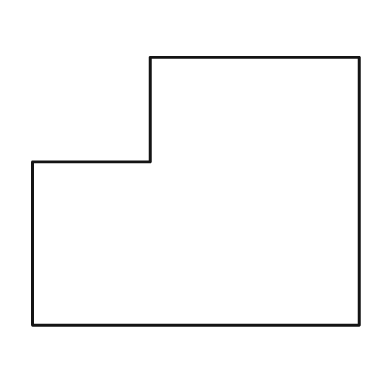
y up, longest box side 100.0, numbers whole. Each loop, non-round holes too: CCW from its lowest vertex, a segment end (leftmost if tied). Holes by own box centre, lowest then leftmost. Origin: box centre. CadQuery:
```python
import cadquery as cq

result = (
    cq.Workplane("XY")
    .moveTo(-50.0, -41.0)
    .lineTo(50.0, -41.0)
    .lineTo(50.0, 41.0)
    .lineTo(-14.0, 41.0)
    .lineTo(-14.0, 9.0)
    .lineTo(-50.0, 9.0)
    .close()
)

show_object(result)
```